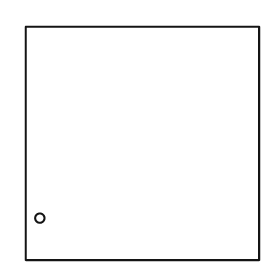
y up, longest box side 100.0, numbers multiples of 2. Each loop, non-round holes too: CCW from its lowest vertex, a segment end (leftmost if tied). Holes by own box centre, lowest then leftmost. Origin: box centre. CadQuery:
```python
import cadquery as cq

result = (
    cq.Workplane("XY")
    .moveTo(-50.0, -50.0)
    .lineTo(50.0, -50.0)
    .lineTo(50.0, 50.0)
    .lineTo(-50.0, 50.0)
    .close()
    .moveTo(-44.0, -32.0)
    .circle(2.0)
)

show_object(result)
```